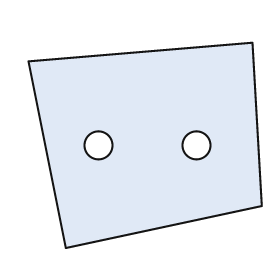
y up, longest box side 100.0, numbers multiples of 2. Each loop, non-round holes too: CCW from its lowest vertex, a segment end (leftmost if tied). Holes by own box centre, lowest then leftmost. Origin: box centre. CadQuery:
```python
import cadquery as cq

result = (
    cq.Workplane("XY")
    .moveTo(-34.0, -44.0)
    .lineTo(50.0, -26.0)
    .lineTo(46.0, 44.0)
    .lineTo(-50.0, 36.0)
    .close()
    .moveTo(-20.0, 0.0)
    .circle(6.0)
    .moveTo(22.0, 0.0)
    .circle(6.0)
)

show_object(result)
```